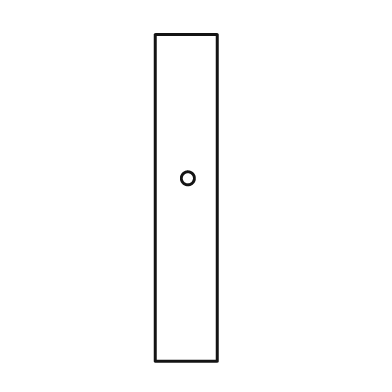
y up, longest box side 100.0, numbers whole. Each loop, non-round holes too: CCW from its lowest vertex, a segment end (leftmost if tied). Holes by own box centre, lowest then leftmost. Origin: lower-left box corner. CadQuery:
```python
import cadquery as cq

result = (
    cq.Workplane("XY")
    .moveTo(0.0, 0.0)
    .lineTo(19.0, 0.0)
    .lineTo(19.0, 100.0)
    .lineTo(0.0, 100.0)
    .close()
    .moveTo(10.0, 56.0)
    .circle(2.0)
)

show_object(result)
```